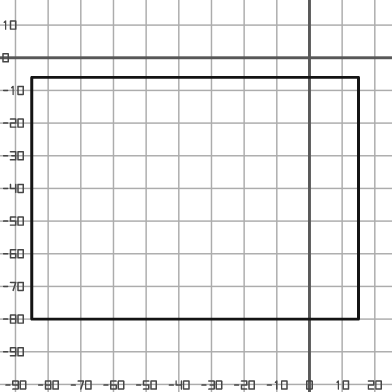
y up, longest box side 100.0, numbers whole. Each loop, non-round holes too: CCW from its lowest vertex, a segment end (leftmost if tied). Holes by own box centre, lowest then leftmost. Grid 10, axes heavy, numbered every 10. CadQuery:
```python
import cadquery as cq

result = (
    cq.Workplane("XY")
    .moveTo(-85.0, -80.0)
    .lineTo(15.0, -80.0)
    .lineTo(15.0, -6.0)
    .lineTo(-85.0, -6.0)
    .close()
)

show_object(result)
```